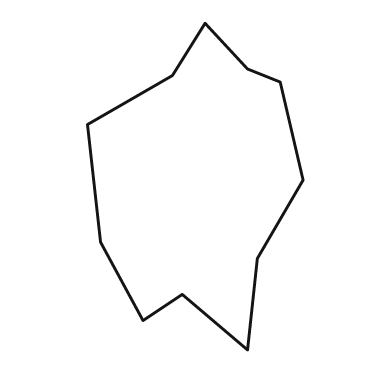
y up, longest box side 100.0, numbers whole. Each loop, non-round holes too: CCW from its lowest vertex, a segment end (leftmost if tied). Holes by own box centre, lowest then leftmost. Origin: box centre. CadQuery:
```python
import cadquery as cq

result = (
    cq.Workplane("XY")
    .moveTo(16.0, -50.0)
    .lineTo(19.0, -22.0)
    .lineTo(33.0, 2.0)
    .lineTo(26.0, 32.0)
    .lineTo(16.0, 36.0)
    .lineTo(3.0, 50.0)
    .lineTo(-7.0, 34.0)
    .lineTo(-33.0, 19.0)
    .lineTo(-29.0, -17.0)
    .lineTo(-16.0, -41.0)
    .lineTo(-4.0, -33.0)
    .close()
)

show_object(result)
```